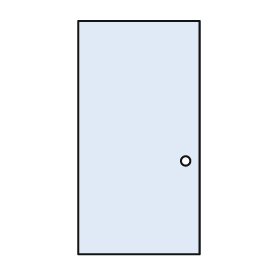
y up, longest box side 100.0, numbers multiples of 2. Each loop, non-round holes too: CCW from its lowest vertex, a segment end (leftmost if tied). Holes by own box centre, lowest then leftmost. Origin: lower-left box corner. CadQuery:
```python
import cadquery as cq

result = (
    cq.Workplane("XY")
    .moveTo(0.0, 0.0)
    .lineTo(52.0, 0.0)
    .lineTo(52.0, 100.0)
    .lineTo(0.0, 100.0)
    .close()
    .moveTo(46.0, 40.0)
    .circle(2.0)
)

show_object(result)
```